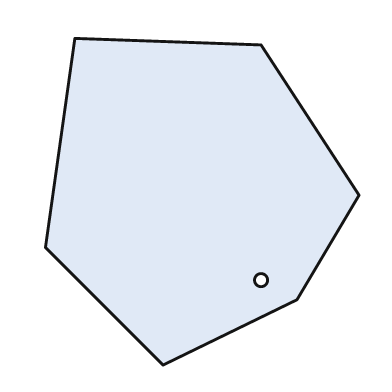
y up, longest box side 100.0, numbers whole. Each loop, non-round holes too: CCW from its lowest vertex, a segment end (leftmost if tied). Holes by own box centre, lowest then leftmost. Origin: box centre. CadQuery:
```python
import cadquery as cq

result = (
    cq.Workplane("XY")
    .moveTo(-12.0, -50.0)
    .lineTo(29.0, -30.0)
    .lineTo(48.0, 2.0)
    .lineTo(18.0, 48.0)
    .lineTo(-39.0, 50.0)
    .lineTo(-48.0, -14.0)
    .close()
    .moveTo(18.0, -24.0)
    .circle(2.0)
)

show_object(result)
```